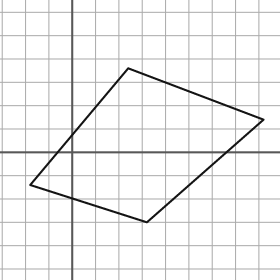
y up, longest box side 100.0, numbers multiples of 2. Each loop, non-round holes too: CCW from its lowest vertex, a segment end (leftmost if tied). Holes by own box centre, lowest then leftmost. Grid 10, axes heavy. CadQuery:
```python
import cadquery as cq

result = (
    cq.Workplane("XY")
    .moveTo(32.0, -30.0)
    .lineTo(82.0, 14.0)
    .lineTo(24.0, 36.0)
    .lineTo(-18.0, -14.0)
    .close()
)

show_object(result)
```